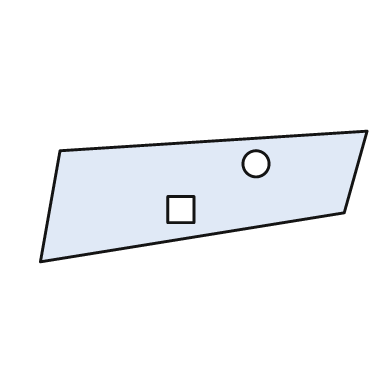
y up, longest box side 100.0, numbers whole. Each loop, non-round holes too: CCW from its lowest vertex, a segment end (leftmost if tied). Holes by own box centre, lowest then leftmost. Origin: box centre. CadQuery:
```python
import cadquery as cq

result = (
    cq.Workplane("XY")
    .moveTo(-50.0, -20.0)
    .lineTo(43.0, -5.0)
    .lineTo(50.0, 20.0)
    .lineTo(-44.0, 14.0)
    .close()
    .moveTo(-11.0, -8.0)
    .lineTo(-3.0, -8.0)
    .lineTo(-3.0, 0.0)
    .lineTo(-11.0, 0.0)
    .close()
    .moveTo(16.0, 10.0)
    .circle(4.0)
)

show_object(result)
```